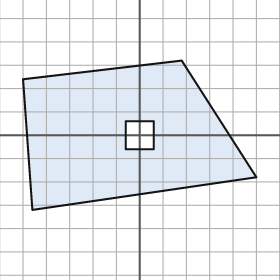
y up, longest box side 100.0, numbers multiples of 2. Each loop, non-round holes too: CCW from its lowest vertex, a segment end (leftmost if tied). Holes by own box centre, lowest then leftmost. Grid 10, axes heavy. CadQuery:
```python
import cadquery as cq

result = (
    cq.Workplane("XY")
    .moveTo(-46.0, -32.0)
    .lineTo(50.0, -18.0)
    .lineTo(18.0, 32.0)
    .lineTo(-50.0, 24.0)
    .close()
    .moveTo(-6.0, -6.0)
    .lineTo(6.0, -6.0)
    .lineTo(6.0, 6.0)
    .lineTo(-6.0, 6.0)
    .close()
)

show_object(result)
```